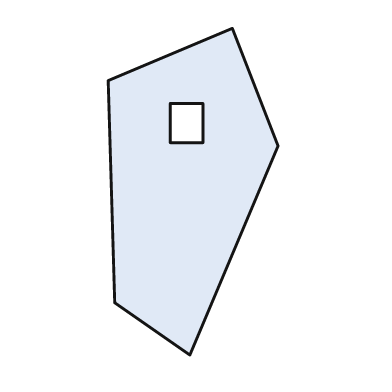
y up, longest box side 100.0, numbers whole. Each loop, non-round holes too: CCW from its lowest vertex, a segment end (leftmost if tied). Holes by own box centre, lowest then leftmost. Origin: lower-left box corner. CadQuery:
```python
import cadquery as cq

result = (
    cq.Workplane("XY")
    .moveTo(25.0, 0.0)
    .lineTo(52.0, 64.0)
    .lineTo(38.0, 100.0)
    .lineTo(0.0, 84.0)
    .lineTo(2.0, 16.0)
    .close()
    .moveTo(19.0, 65.0)
    .lineTo(29.0, 65.0)
    .lineTo(29.0, 77.0)
    .lineTo(19.0, 77.0)
    .close()
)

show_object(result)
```